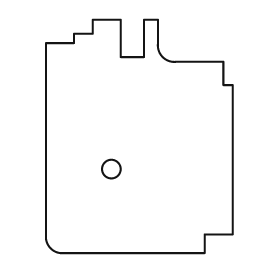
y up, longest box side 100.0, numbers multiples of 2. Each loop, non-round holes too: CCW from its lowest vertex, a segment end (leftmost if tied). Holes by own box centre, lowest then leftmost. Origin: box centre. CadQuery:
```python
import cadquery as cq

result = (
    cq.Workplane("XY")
    .moveTo(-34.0, -50.0)
    .lineTo(28.0, -50.0)
    .lineTo(28.0, -42.0)
    .lineTo(40.0, -42.0)
    .lineTo(40.0, 22.0)
    .lineTo(36.0, 22.0)
    .lineTo(36.0, 32.0)
    .lineTo(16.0, 32.0)
    .threePointArc((10.0, 34.0), (8.0, 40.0))
    .lineTo(8.0, 50.0)
    .lineTo(2.0, 50.0)
    .lineTo(2.0, 34.0)
    .lineTo(-8.0, 34.0)
    .lineTo(-8.0, 50.0)
    .lineTo(-20.0, 50.0)
    .lineTo(-20.0, 44.0)
    .lineTo(-28.0, 44.0)
    .lineTo(-28.0, 40.0)
    .lineTo(-40.0, 40.0)
    .lineTo(-40.0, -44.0)
    .threePointArc((-38.0, -48.0), (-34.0, -50.0))
    .close()
    .moveTo(-12.0, -14.0)
    .circle(4.0)
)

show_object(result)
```